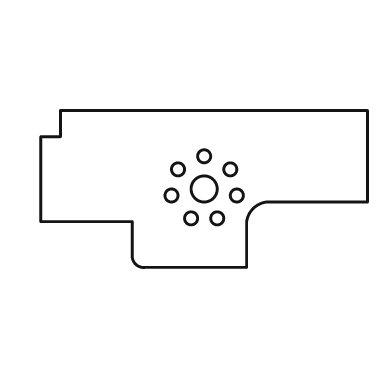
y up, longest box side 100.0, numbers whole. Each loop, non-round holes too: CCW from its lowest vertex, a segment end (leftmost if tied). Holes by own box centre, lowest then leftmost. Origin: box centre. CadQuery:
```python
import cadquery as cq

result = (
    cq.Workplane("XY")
    .moveTo(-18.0, -24.0)
    .lineTo(13.0, -24.0)
    .lineTo(13.0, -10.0)
    .threePointArc((15.0, -6.0), (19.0, -4.0))
    .lineTo(50.0, -4.0)
    .lineTo(50.0, 24.0)
    .lineTo(-44.0, 24.0)
    .lineTo(-44.0, 16.0)
    .lineTo(-50.0, 16.0)
    .lineTo(-50.0, -10.0)
    .lineTo(-22.0, -10.0)
    .lineTo(-22.0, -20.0)
    .threePointArc((-21.0, -23.0), (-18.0, -24.0))
    .close()
    .moveTo(-4.0, -9.0)
    .circle(2.0)
    .moveTo(4.0, -9.0)
    .circle(2.0)
    .moveTo(-10.0, -2.0)
    .circle(2.0)
    .moveTo(10.0, -2.0)
    .circle(2.0)
    .moveTo(0.0, 0.0)
    .circle(4.0)
    .moveTo(-8.0, 6.0)
    .circle(2.0)
    .moveTo(8.0, 6.0)
    .circle(2.0)
    .moveTo(0.0, 10.0)
    .circle(2.0)
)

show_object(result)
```